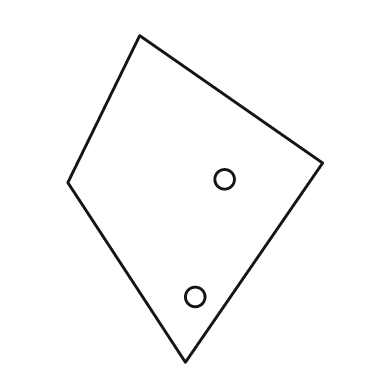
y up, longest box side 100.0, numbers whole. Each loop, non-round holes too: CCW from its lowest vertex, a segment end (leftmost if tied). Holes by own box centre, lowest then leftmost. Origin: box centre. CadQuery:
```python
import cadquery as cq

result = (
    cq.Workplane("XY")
    .moveTo(-3.0, -50.0)
    .lineTo(39.0, 11.0)
    .lineTo(-17.0, 50.0)
    .lineTo(-39.0, 5.0)
    .close()
    .moveTo(0.0, -30.0)
    .circle(3.0)
    .moveTo(9.0, 6.0)
    .circle(3.0)
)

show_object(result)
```